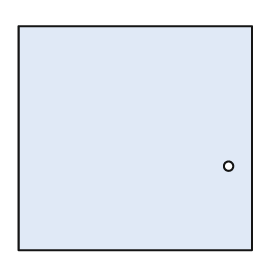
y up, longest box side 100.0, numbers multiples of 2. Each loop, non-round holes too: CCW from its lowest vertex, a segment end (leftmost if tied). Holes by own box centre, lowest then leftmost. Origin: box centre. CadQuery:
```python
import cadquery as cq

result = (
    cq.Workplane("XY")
    .moveTo(-50.0, -48.0)
    .lineTo(50.0, -48.0)
    .lineTo(50.0, 48.0)
    .lineTo(-50.0, 48.0)
    .close()
    .moveTo(40.0, -12.0)
    .circle(2.0)
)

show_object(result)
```